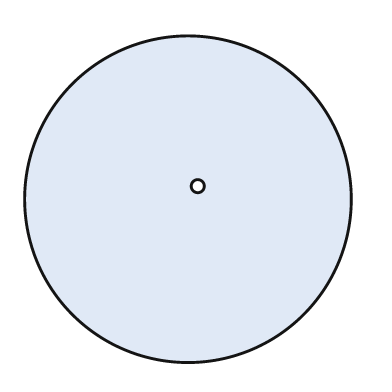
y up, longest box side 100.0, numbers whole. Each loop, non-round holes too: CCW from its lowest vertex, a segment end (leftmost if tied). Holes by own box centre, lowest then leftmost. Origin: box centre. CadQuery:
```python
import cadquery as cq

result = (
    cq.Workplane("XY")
    .moveTo(0.0, 0.0)
    .circle(50.0)
    .moveTo(3.0, 4.0)
    .circle(2.0)
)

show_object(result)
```